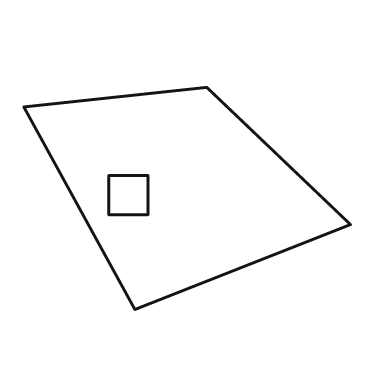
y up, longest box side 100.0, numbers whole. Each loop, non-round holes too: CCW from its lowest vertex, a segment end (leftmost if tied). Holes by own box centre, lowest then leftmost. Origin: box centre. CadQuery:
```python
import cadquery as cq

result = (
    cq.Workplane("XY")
    .moveTo(-16.0, -34.0)
    .lineTo(50.0, -8.0)
    .lineTo(6.0, 34.0)
    .lineTo(-50.0, 28.0)
    .close()
    .moveTo(-24.0, -5.0)
    .lineTo(-12.0, -5.0)
    .lineTo(-12.0, 7.0)
    .lineTo(-24.0, 7.0)
    .close()
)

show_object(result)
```